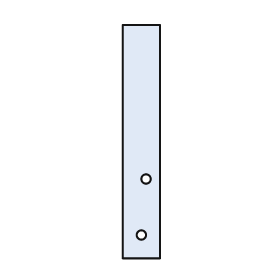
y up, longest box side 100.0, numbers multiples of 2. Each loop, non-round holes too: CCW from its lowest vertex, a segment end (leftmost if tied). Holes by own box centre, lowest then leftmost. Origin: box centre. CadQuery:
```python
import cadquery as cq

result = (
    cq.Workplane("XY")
    .moveTo(-8.0, -50.0)
    .lineTo(8.0, -50.0)
    .lineTo(8.0, 50.0)
    .lineTo(-8.0, 50.0)
    .close()
    .moveTo(0.0, -40.0)
    .circle(2.0)
    .moveTo(2.0, -16.0)
    .circle(2.0)
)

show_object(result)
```